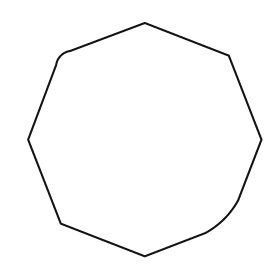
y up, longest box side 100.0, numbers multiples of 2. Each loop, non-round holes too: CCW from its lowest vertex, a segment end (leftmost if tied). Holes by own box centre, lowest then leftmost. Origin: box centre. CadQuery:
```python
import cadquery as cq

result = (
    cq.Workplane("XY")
    .moveTo(0.0, -50.0)
    .lineTo(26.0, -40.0)
    .threePointArc((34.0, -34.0), (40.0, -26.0))
    .lineTo(50.0, 0.0)
    .lineTo(36.0, 36.0)
    .lineTo(0.0, 50.0)
    .lineTo(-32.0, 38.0)
    .threePointArc((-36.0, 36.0), (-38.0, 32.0))
    .lineTo(-50.0, 0.0)
    .lineTo(-36.0, -36.0)
    .close()
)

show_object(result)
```